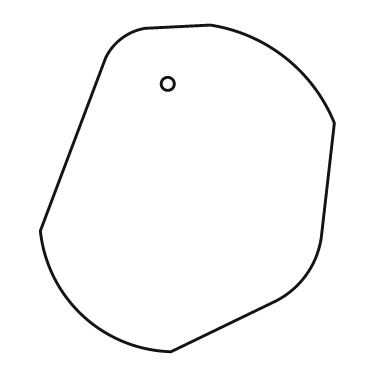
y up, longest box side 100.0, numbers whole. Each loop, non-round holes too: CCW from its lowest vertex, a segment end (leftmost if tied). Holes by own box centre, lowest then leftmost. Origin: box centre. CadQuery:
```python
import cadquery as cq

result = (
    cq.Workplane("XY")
    .moveTo(-5.0, -50.0)
    .lineTo(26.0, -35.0)
    .threePointArc((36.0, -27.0), (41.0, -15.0))
    .lineTo(45.0, 20.0)
    .threePointArc((30.0, 40.0), (7.0, 50.0))
    .lineTo(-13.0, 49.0)
    .threePointArc((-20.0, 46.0), (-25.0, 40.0))
    .lineTo(-45.0, -13.0)
    .threePointArc((-32.0, -39.0), (-5.0, -50.0))
    .close()
    .moveTo(-6.0, 32.0)
    .circle(2.0)
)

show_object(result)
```